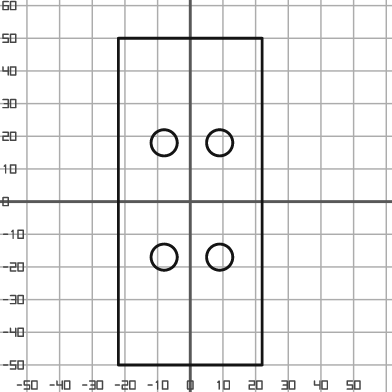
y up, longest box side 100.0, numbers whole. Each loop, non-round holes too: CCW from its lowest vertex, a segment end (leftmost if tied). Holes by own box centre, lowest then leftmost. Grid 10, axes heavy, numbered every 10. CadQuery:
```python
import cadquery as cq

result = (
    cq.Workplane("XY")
    .moveTo(-22.0, -50.0)
    .lineTo(22.0, -50.0)
    .lineTo(22.0, 50.0)
    .lineTo(-22.0, 50.0)
    .close()
    .moveTo(-8.0, -17.0)
    .circle(4.0)
    .moveTo(9.0, -17.0)
    .circle(4.0)
    .moveTo(-8.0, 18.0)
    .circle(4.0)
    .moveTo(9.0, 18.0)
    .circle(4.0)
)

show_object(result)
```